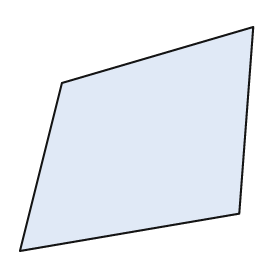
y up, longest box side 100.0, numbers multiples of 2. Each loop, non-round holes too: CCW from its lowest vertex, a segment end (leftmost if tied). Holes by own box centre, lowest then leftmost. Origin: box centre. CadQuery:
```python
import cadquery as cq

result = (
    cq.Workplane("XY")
    .moveTo(-50.0, -48.0)
    .lineTo(44.0, -32.0)
    .lineTo(50.0, 48.0)
    .lineTo(-32.0, 24.0)
    .close()
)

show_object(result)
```